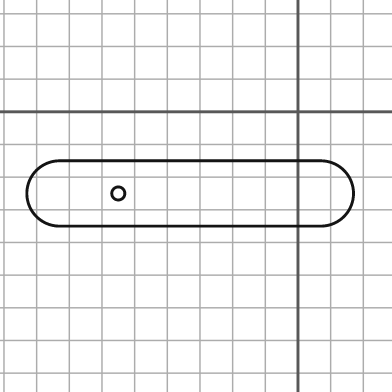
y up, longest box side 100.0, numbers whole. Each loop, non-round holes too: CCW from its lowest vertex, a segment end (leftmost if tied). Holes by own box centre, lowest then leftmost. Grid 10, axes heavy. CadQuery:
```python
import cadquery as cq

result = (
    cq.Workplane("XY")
    .moveTo(-73.0, -35.0)
    .lineTo(7.0, -35.0)
    .threePointArc((17.0, -25.0), (7.0, -15.0))
    .lineTo(-73.0, -15.0)
    .threePointArc((-83.0, -25.0), (-73.0, -35.0))
    .close()
    .moveTo(-55.0, -25.0)
    .circle(2.0)
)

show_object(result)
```